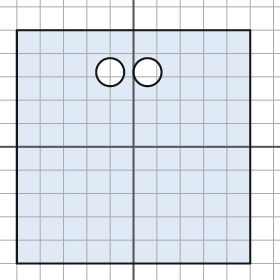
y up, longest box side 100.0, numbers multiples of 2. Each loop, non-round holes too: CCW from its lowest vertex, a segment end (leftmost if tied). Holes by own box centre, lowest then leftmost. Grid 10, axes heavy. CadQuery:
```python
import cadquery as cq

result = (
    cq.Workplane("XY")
    .moveTo(-50.0, -50.0)
    .lineTo(50.0, -50.0)
    .lineTo(50.0, 50.0)
    .lineTo(-50.0, 50.0)
    .close()
    .moveTo(-10.0, 32.0)
    .circle(6.0)
    .moveTo(6.0, 32.0)
    .circle(6.0)
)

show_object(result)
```